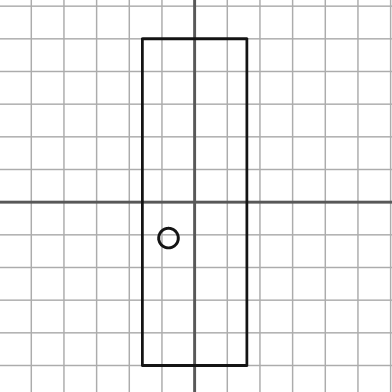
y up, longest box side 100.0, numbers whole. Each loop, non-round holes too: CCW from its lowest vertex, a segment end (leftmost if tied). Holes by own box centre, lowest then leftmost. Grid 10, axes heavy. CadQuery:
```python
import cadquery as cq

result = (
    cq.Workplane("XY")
    .moveTo(-16.0, -50.0)
    .lineTo(16.0, -50.0)
    .lineTo(16.0, 50.0)
    .lineTo(-16.0, 50.0)
    .close()
    .moveTo(-8.0, -11.0)
    .circle(3.0)
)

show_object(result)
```